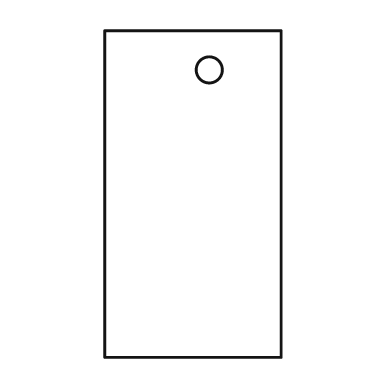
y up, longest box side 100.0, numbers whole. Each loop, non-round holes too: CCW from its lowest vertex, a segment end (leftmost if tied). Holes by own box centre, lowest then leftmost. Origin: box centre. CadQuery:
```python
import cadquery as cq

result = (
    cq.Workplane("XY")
    .moveTo(-27.0, -50.0)
    .lineTo(27.0, -50.0)
    .lineTo(27.0, 50.0)
    .lineTo(-27.0, 50.0)
    .close()
    .moveTo(5.0, 38.0)
    .circle(4.0)
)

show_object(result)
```